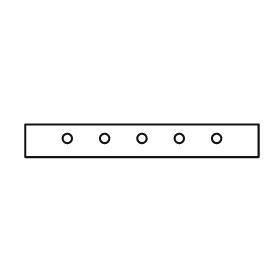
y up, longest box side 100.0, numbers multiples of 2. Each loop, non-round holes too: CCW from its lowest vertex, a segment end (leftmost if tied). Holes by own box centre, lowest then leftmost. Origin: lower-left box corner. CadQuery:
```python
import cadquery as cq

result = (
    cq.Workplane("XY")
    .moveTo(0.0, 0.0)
    .lineTo(100.0, 0.0)
    .lineTo(100.0, 14.0)
    .lineTo(0.0, 14.0)
    .close()
    .moveTo(18.0, 8.0)
    .circle(2.0)
    .moveTo(34.0, 8.0)
    .circle(2.0)
    .moveTo(50.0, 8.0)
    .circle(2.0)
    .moveTo(66.0, 8.0)
    .circle(2.0)
    .moveTo(82.0, 8.0)
    .circle(2.0)
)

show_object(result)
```